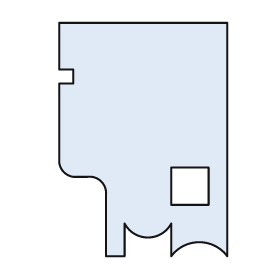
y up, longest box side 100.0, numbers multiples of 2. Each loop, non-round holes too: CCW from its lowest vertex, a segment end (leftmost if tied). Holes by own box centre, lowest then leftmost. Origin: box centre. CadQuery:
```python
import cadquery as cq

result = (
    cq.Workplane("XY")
    .moveTo(-16.0, -50.0)
    .lineTo(-8.0, -50.0)
    .lineTo(-8.0, -36.0)
    .threePointArc((2.0, -42.0), (12.0, -36.0))
    .lineTo(12.0, -50.0)
    .threePointArc((24.0, -44.0), (36.0, -50.0))
    .lineTo(36.0, 50.0)
    .lineTo(-36.0, 50.0)
    .lineTo(-36.0, 30.0)
    .lineTo(-30.0, 30.0)
    .lineTo(-30.0, 24.0)
    .lineTo(-36.0, 24.0)
    .lineTo(-36.0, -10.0)
    .threePointArc((-34.0, -14.0), (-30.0, -16.0))
    .lineTo(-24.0, -16.0)
    .threePointArc((-18.0, -18.0), (-16.0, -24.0))
    .close()
    .moveTo(12.0, -28.0)
    .lineTo(28.0, -28.0)
    .lineTo(28.0, -12.0)
    .lineTo(12.0, -12.0)
    .close()
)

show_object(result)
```